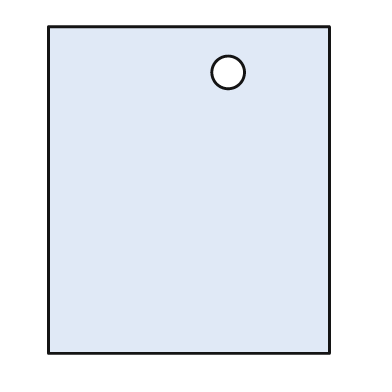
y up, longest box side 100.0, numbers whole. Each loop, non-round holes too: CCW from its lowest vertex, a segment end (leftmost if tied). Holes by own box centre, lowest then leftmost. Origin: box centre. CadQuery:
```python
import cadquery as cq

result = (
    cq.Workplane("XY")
    .moveTo(-43.0, -50.0)
    .lineTo(43.0, -50.0)
    .lineTo(43.0, 50.0)
    .lineTo(-43.0, 50.0)
    .close()
    .moveTo(12.0, 36.0)
    .circle(5.0)
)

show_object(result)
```